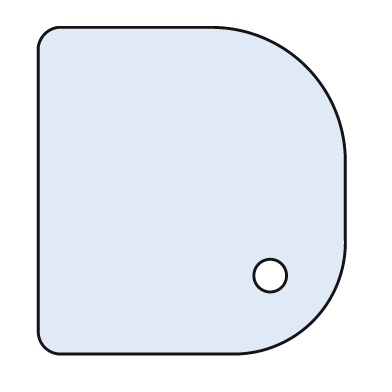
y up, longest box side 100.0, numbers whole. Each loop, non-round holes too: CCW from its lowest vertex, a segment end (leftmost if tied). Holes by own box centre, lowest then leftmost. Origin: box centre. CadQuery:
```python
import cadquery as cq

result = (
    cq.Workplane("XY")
    .moveTo(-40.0, -50.0)
    .lineTo(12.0, -50.0)
    .threePointArc((37.0, -40.0), (47.0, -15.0))
    .lineTo(47.0, 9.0)
    .threePointArc((35.0, 38.0), (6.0, 50.0))
    .lineTo(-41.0, 50.0)
    .threePointArc((-45.0, 48.0), (-47.0, 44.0))
    .lineTo(-47.0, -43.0)
    .threePointArc((-45.0, -48.0), (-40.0, -50.0))
    .close()
    .moveTo(24.0, -26.0)
    .circle(5.0)
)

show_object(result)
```